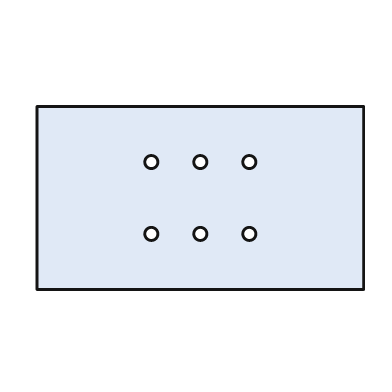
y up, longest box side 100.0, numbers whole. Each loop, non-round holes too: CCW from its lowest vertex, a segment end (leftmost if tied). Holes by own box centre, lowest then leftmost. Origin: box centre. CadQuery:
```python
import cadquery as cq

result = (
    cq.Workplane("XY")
    .moveTo(-50.0, -28.0)
    .lineTo(50.0, -28.0)
    .lineTo(50.0, 28.0)
    .lineTo(-50.0, 28.0)
    .close()
    .moveTo(-15.0, -11.0)
    .circle(2.0)
    .moveTo(0.0, -11.0)
    .circle(2.0)
    .moveTo(15.0, -11.0)
    .circle(2.0)
    .moveTo(-15.0, 11.0)
    .circle(2.0)
    .moveTo(0.0, 11.0)
    .circle(2.0)
    .moveTo(15.0, 11.0)
    .circle(2.0)
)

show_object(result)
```